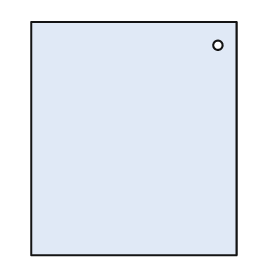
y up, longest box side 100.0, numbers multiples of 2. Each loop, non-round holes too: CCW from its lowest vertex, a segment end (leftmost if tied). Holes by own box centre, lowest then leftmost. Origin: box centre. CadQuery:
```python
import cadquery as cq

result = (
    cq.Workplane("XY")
    .moveTo(-44.0, -50.0)
    .lineTo(44.0, -50.0)
    .lineTo(44.0, 50.0)
    .lineTo(-44.0, 50.0)
    .close()
    .moveTo(36.0, 40.0)
    .circle(2.0)
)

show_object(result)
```